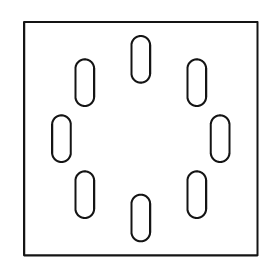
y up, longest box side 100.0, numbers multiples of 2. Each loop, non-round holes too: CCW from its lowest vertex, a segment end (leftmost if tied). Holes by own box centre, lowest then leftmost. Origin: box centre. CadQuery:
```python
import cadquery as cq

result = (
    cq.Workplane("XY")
    .moveTo(-50.0, -50.0)
    .lineTo(50.0, -50.0)
    .lineTo(50.0, 50.0)
    .lineTo(-50.0, 50.0)
    .close()
    .moveTo(-4.0, -40.0)
    .threePointArc((0.0, -44.0), (4.0, -40.0))
    .lineTo(4.0, -28.0)
    .threePointArc((0.0, -24.0), (-4.0, -28.0))
    .close()
    .moveTo(-28.0, -30.0)
    .threePointArc((-24.0, -34.0), (-20.0, -30.0))
    .lineTo(-20.0, -18.0)
    .threePointArc((-24.0, -14.0), (-28.0, -18.0))
    .close()
    .moveTo(20.0, -30.0)
    .threePointArc((24.0, -34.0), (28.0, -30.0))
    .lineTo(28.0, -18.0)
    .threePointArc((24.0, -14.0), (20.0, -18.0))
    .close()
    .moveTo(-38.0, -6.0)
    .threePointArc((-34.0, -10.0), (-30.0, -6.0))
    .lineTo(-30.0, 6.0)
    .threePointArc((-34.0, 10.0), (-38.0, 6.0))
    .close()
    .moveTo(30.0, -6.0)
    .threePointArc((34.0, -10.0), (38.0, -6.0))
    .lineTo(38.0, 6.0)
    .threePointArc((34.0, 10.0), (30.0, 6.0))
    .close()
    .moveTo(-28.0, 18.0)
    .threePointArc((-24.0, 14.0), (-20.0, 18.0))
    .lineTo(-20.0, 30.0)
    .threePointArc((-24.0, 34.0), (-28.0, 30.0))
    .close()
    .moveTo(20.0, 18.0)
    .threePointArc((24.0, 14.0), (28.0, 18.0))
    .lineTo(28.0, 30.0)
    .threePointArc((24.0, 34.0), (20.0, 30.0))
    .close()
    .moveTo(-4.0, 28.0)
    .threePointArc((0.0, 24.0), (4.0, 28.0))
    .lineTo(4.0, 40.0)
    .threePointArc((0.0, 44.0), (-4.0, 40.0))
    .close()
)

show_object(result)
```